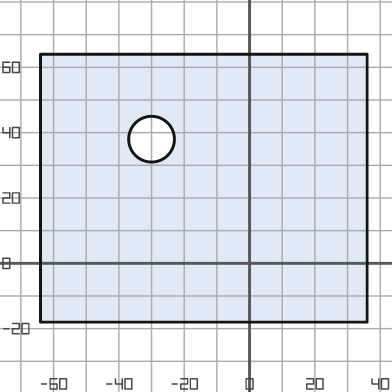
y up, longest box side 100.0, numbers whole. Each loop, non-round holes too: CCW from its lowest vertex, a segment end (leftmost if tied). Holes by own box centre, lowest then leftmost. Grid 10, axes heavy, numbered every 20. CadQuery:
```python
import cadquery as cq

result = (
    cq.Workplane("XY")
    .moveTo(-64.0, -18.0)
    .lineTo(36.0, -18.0)
    .lineTo(36.0, 64.0)
    .lineTo(-64.0, 64.0)
    .close()
    .moveTo(-30.0, 38.0)
    .circle(7.0)
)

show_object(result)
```